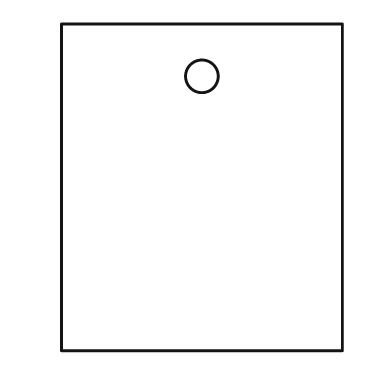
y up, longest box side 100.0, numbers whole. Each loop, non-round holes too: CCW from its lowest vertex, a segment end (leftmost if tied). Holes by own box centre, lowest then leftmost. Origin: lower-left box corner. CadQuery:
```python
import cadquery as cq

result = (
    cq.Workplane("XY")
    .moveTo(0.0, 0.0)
    .lineTo(86.0, 0.0)
    .lineTo(86.0, 100.0)
    .lineTo(0.0, 100.0)
    .close()
    .moveTo(43.0, 84.0)
    .circle(5.0)
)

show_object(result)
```